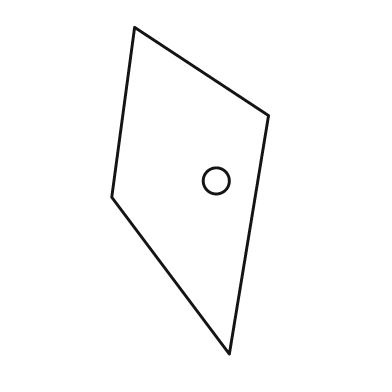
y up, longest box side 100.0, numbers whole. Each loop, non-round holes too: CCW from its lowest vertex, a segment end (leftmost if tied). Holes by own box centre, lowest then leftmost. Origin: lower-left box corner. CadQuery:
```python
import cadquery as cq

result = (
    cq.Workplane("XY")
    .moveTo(36.0, 0.0)
    .lineTo(48.0, 73.0)
    .lineTo(7.0, 100.0)
    .lineTo(0.0, 48.0)
    .close()
    .moveTo(32.0, 53.0)
    .circle(4.0)
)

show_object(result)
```